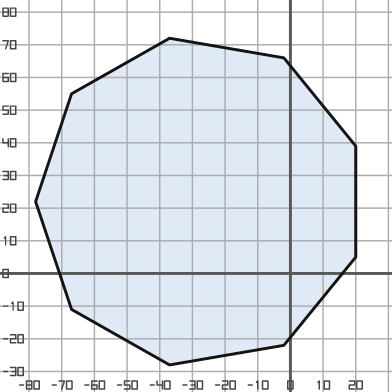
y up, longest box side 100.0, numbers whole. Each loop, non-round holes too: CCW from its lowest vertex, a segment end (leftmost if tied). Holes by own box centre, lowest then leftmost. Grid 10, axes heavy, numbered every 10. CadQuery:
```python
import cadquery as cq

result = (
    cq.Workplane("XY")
    .moveTo(-37.0, -28.0)
    .lineTo(-2.0, -22.0)
    .lineTo(20.0, 5.0)
    .lineTo(20.0, 39.0)
    .lineTo(-2.0, 66.0)
    .lineTo(-37.0, 72.0)
    .lineTo(-67.0, 55.0)
    .lineTo(-78.0, 22.0)
    .lineTo(-67.0, -11.0)
    .close()
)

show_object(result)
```